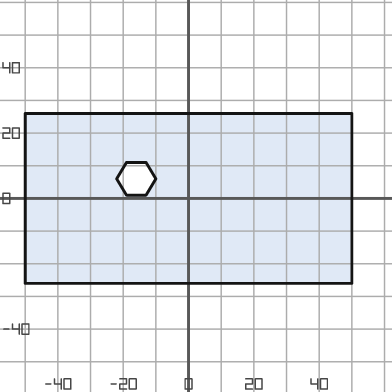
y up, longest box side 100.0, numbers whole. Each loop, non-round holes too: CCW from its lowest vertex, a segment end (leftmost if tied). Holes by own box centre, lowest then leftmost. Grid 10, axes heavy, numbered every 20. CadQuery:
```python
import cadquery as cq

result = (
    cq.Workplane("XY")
    .moveTo(-50.0, -26.0)
    .lineTo(50.0, -26.0)
    .lineTo(50.0, 26.0)
    .lineTo(-50.0, 26.0)
    .close()
    .moveTo(-19.0, 1.0)
    .lineTo(-13.0, 1.0)
    .lineTo(-10.0, 6.0)
    .lineTo(-13.0, 11.0)
    .lineTo(-19.0, 11.0)
    .lineTo(-22.0, 6.0)
    .close()
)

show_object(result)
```